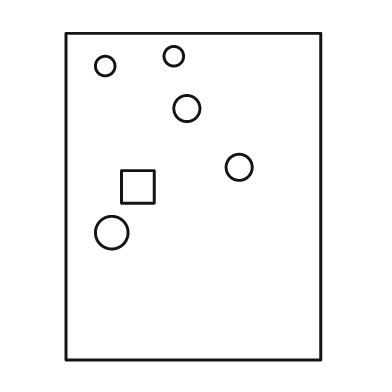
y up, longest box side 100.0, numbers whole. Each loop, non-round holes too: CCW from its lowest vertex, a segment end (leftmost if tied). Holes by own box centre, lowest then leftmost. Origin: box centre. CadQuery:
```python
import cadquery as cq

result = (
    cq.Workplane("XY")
    .moveTo(-39.0, -50.0)
    .lineTo(39.0, -50.0)
    .lineTo(39.0, 50.0)
    .lineTo(-39.0, 50.0)
    .close()
    .moveTo(-25.0, -11.0)
    .circle(5.0)
    .moveTo(-22.0, -2.0)
    .lineTo(-12.0, -2.0)
    .lineTo(-12.0, 8.0)
    .lineTo(-22.0, 8.0)
    .close()
    .moveTo(14.0, 9.0)
    .circle(4.0)
    .moveTo(-2.0, 27.0)
    .circle(4.0)
    .moveTo(-27.0, 40.0)
    .circle(3.0)
    .moveTo(-6.0, 43.0)
    .circle(3.0)
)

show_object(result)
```